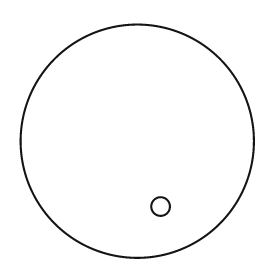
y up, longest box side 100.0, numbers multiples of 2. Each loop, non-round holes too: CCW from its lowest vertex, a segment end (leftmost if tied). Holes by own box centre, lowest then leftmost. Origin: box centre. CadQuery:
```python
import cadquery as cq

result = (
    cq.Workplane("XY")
    .moveTo(0.0, 0.0)
    .circle(50.0)
    .moveTo(10.0, -28.0)
    .circle(4.0)
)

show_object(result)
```